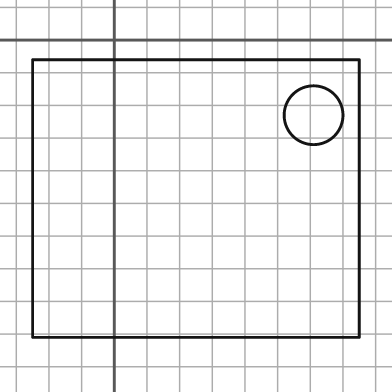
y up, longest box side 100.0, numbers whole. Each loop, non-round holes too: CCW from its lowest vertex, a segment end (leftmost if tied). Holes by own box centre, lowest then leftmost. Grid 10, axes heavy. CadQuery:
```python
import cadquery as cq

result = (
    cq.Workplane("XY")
    .moveTo(-25.0, -91.0)
    .lineTo(75.0, -91.0)
    .lineTo(75.0, -6.0)
    .lineTo(-25.0, -6.0)
    .close()
    .moveTo(61.0, -23.0)
    .circle(9.0)
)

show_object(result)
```